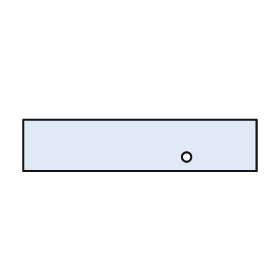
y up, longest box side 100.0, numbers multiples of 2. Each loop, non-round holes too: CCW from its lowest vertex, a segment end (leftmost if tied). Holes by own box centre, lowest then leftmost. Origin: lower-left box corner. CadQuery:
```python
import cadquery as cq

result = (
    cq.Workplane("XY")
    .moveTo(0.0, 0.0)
    .lineTo(100.0, 0.0)
    .lineTo(100.0, 22.0)
    .lineTo(0.0, 22.0)
    .close()
    .moveTo(70.0, 6.0)
    .circle(2.0)
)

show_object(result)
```